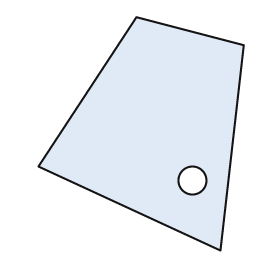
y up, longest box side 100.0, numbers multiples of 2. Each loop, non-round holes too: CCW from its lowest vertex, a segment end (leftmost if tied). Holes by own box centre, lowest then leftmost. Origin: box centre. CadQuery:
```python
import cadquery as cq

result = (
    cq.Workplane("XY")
    .moveTo(34.0, -50.0)
    .lineTo(44.0, 38.0)
    .lineTo(-2.0, 50.0)
    .lineTo(-44.0, -14.0)
    .close()
    .moveTo(22.0, -20.0)
    .circle(6.0)
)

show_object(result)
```